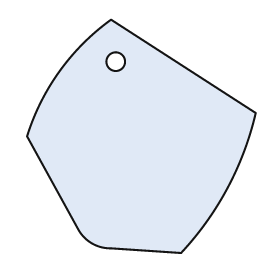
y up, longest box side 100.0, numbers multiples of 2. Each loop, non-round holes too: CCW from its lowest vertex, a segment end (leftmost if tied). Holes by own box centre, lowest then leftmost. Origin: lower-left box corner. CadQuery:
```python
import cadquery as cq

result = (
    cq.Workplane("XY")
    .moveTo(66.0, 0.0)
    .threePointArc((86.0, 28.0), (98.0, 60.0))
    .lineTo(36.0, 100.0)
    .threePointArc((14.0, 78.0), (0.0, 50.0))
    .lineTo(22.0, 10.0)
    .threePointArc((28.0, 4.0), (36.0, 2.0))
    .close()
    .moveTo(38.0, 82.0)
    .circle(4.0)
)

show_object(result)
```